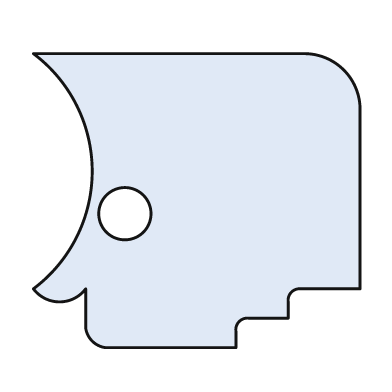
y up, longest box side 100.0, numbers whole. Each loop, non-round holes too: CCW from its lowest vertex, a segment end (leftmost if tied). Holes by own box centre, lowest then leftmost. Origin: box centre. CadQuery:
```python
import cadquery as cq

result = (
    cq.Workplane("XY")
    .moveTo(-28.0, -45.0)
    .lineTo(12.0, -45.0)
    .lineTo(12.0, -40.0)
    .threePointArc((13.0, -37.0), (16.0, -36.0))
    .lineTo(28.0, -36.0)
    .lineTo(28.0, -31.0)
    .threePointArc((29.0, -28.0), (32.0, -27.0))
    .lineTo(50.0, -27.0)
    .lineTo(50.0, 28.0)
    .threePointArc((45.0, 40.0), (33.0, 45.0))
    .lineTo(-50.0, 45.0)
    .threePointArc((-32.0, 9.0), (-50.0, -27.0))
    .threePointArc((-42.0, -31.0), (-34.0, -27.0))
    .lineTo(-34.0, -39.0)
    .threePointArc((-32.0, -43.0), (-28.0, -45.0))
    .close()
    .moveTo(-22.0, -4.0)
    .circle(8.0)
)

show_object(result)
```